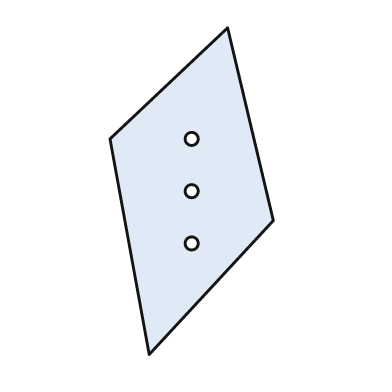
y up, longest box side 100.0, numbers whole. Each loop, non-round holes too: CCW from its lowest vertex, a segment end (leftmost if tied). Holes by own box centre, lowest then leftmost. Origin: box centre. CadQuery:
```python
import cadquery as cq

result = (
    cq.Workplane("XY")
    .moveTo(-13.0, -50.0)
    .lineTo(25.0, -9.0)
    .lineTo(11.0, 50.0)
    .lineTo(-25.0, 16.0)
    .close()
    .moveTo(0.0, -16.0)
    .circle(2.0)
    .moveTo(0.0, 0.0)
    .circle(2.0)
    .moveTo(0.0, 16.0)
    .circle(2.0)
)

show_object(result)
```